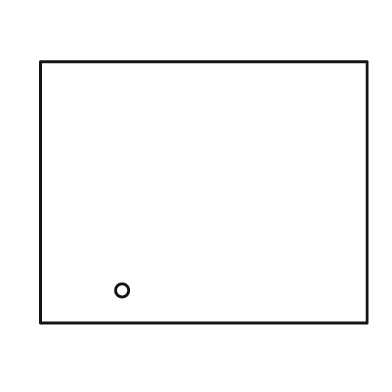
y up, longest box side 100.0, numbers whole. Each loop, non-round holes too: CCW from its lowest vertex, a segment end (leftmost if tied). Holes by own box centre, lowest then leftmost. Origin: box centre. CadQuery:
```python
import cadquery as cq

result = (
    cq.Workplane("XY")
    .moveTo(-50.0, -40.0)
    .lineTo(50.0, -40.0)
    .lineTo(50.0, 40.0)
    .lineTo(-50.0, 40.0)
    .close()
    .moveTo(-25.0, -30.0)
    .circle(2.0)
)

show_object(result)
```